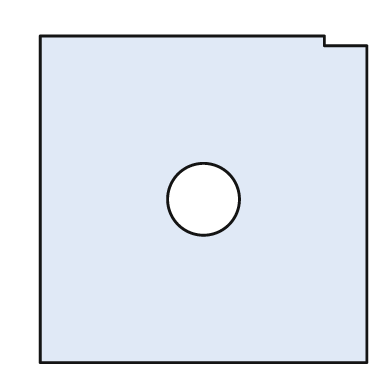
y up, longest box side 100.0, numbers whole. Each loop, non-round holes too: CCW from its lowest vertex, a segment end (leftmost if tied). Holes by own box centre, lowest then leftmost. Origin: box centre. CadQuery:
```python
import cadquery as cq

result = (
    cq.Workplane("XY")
    .moveTo(-50.0, -50.0)
    .lineTo(50.0, -50.0)
    .lineTo(50.0, 47.0)
    .lineTo(37.0, 47.0)
    .lineTo(37.0, 50.0)
    .lineTo(-50.0, 50.0)
    .close()
    .moveTo(0.0, 0.0)
    .circle(11.0)
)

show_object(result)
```